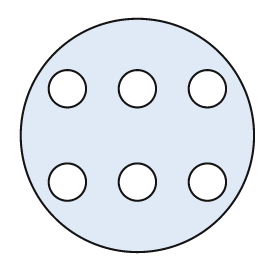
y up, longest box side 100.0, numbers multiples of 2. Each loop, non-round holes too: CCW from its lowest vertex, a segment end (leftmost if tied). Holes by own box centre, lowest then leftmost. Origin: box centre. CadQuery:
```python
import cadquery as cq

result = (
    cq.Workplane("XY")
    .moveTo(0.0, 0.0)
    .circle(50.0)
    .moveTo(-30.0, -20.0)
    .circle(8.0)
    .moveTo(0.0, -20.0)
    .circle(8.0)
    .moveTo(30.0, -20.0)
    .circle(8.0)
    .moveTo(-30.0, 20.0)
    .circle(8.0)
    .moveTo(0.0, 20.0)
    .circle(8.0)
    .moveTo(30.0, 20.0)
    .circle(8.0)
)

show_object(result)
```